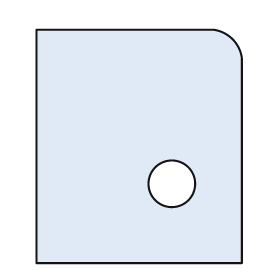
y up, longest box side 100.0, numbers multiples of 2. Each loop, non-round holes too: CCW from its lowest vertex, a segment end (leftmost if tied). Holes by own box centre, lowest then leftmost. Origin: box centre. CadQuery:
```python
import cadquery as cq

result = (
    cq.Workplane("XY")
    .moveTo(-44.0, -50.0)
    .lineTo(44.0, -50.0)
    .lineTo(44.0, 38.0)
    .threePointArc((40.0, 46.0), (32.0, 50.0))
    .lineTo(-44.0, 50.0)
    .close()
    .moveTo(14.0, -16.0)
    .circle(10.0)
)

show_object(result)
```